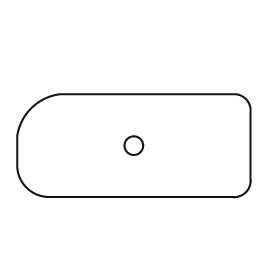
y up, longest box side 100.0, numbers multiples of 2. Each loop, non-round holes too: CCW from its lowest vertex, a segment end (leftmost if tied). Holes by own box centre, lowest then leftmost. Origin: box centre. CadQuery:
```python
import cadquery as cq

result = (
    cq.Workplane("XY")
    .moveTo(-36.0, -22.0)
    .lineTo(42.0, -22.0)
    .threePointArc((48.0, -20.0), (50.0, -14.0))
    .lineTo(50.0, 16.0)
    .threePointArc((48.0, 20.0), (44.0, 22.0))
    .lineTo(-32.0, 22.0)
    .threePointArc((-44.0, 16.0), (-50.0, 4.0))
    .lineTo(-50.0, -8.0)
    .threePointArc((-46.0, -18.0), (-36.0, -22.0))
    .close()
    .moveTo(0.0, 0.0)
    .circle(4.0)
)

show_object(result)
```